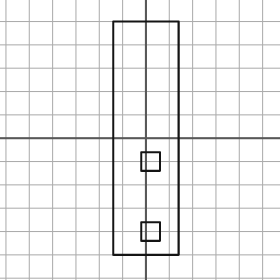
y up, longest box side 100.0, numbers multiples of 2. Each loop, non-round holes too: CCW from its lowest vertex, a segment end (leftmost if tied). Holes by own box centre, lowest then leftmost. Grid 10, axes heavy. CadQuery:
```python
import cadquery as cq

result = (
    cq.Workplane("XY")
    .moveTo(-14.0, -50.0)
    .lineTo(14.0, -50.0)
    .lineTo(14.0, 50.0)
    .lineTo(-14.0, 50.0)
    .close()
    .moveTo(-2.0, -44.0)
    .lineTo(6.0, -44.0)
    .lineTo(6.0, -36.0)
    .lineTo(-2.0, -36.0)
    .close()
    .moveTo(-2.0, -14.0)
    .lineTo(6.0, -14.0)
    .lineTo(6.0, -6.0)
    .lineTo(-2.0, -6.0)
    .close()
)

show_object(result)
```